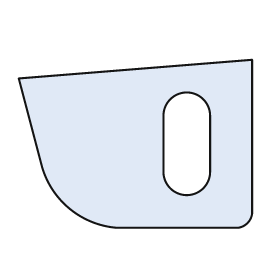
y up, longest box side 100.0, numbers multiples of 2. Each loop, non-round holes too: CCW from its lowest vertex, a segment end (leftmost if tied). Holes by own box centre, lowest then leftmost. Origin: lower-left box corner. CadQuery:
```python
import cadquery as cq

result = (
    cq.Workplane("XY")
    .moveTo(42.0, 0.0)
    .lineTo(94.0, 0.0)
    .threePointArc((98.0, 2.0), (100.0, 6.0))
    .lineTo(100.0, 72.0)
    .lineTo(0.0, 64.0)
    .lineTo(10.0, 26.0)
    .threePointArc((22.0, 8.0), (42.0, 0.0))
    .close()
    .moveTo(62.0, 24.0)
    .threePointArc((72.0, 14.0), (82.0, 24.0))
    .lineTo(82.0, 48.0)
    .threePointArc((72.0, 58.0), (62.0, 48.0))
    .close()
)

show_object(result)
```